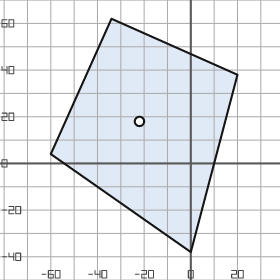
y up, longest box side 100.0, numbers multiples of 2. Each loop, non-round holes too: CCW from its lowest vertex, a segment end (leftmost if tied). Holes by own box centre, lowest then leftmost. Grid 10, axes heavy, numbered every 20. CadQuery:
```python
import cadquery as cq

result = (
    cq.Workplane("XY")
    .moveTo(0.0, -38.0)
    .lineTo(20.0, 38.0)
    .lineTo(-34.0, 62.0)
    .lineTo(-60.0, 4.0)
    .close()
    .moveTo(-22.0, 18.0)
    .circle(2.0)
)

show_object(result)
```